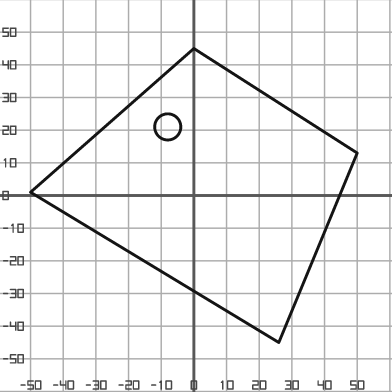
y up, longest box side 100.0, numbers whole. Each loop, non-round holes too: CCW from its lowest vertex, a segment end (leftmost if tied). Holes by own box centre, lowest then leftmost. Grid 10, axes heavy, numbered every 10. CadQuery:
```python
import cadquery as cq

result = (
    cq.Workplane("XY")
    .moveTo(26.0, -45.0)
    .lineTo(50.0, 13.0)
    .lineTo(0.0, 45.0)
    .lineTo(-50.0, 1.0)
    .close()
    .moveTo(-8.0, 21.0)
    .circle(4.0)
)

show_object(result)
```